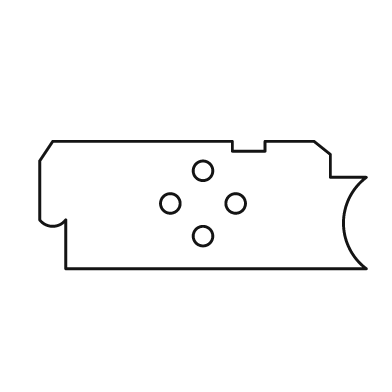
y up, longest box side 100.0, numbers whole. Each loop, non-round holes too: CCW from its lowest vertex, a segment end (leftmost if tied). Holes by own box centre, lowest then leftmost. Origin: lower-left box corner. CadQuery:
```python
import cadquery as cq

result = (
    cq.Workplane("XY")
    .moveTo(8.0, 0.0)
    .lineTo(100.0, 0.0)
    .threePointArc((93.0, 14.0), (100.0, 28.0))
    .lineTo(89.0, 28.0)
    .lineTo(89.0, 35.0)
    .lineTo(84.0, 39.0)
    .lineTo(69.0, 39.0)
    .lineTo(69.0, 36.0)
    .lineTo(59.0, 36.0)
    .lineTo(59.0, 39.0)
    .lineTo(4.0, 39.0)
    .lineTo(0.0, 33.0)
    .lineTo(0.0, 15.0)
    .threePointArc((4.0, 13.0), (8.0, 15.0))
    .close()
    .moveTo(50.0, 10.0)
    .circle(3.0)
    .moveTo(40.0, 20.0)
    .circle(3.0)
    .moveTo(60.0, 20.0)
    .circle(3.0)
    .moveTo(50.0, 30.0)
    .circle(3.0)
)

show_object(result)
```